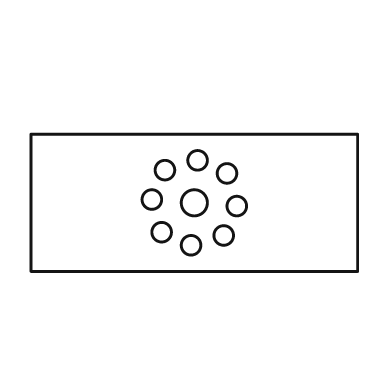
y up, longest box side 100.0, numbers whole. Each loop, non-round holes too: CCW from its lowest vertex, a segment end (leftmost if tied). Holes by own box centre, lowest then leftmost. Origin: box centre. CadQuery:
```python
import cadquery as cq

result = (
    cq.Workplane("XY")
    .moveTo(-50.0, -21.0)
    .lineTo(50.0, -21.0)
    .lineTo(50.0, 21.0)
    .lineTo(-50.0, 21.0)
    .close()
    .moveTo(-1.0, -13.0)
    .circle(3.0)
    .moveTo(9.0, -10.0)
    .circle(3.0)
    .moveTo(-10.0, -9.0)
    .circle(3.0)
    .moveTo(13.0, -1.0)
    .circle(3.0)
    .moveTo(0.0, 0.0)
    .circle(4.0)
    .moveTo(-13.0, 1.0)
    .circle(3.0)
    .moveTo(10.0, 9.0)
    .circle(3.0)
    .moveTo(-9.0, 10.0)
    .circle(3.0)
    .moveTo(1.0, 13.0)
    .circle(3.0)
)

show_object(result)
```